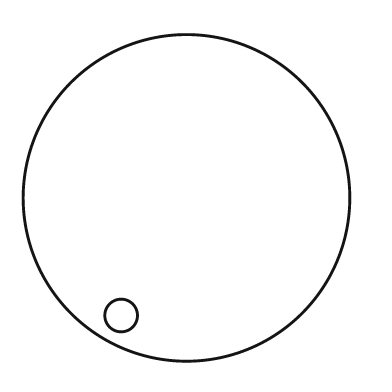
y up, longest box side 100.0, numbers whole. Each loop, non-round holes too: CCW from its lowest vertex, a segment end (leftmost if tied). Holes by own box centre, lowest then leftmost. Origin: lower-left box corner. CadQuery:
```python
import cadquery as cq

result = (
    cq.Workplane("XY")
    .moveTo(50.0, 50.0)
    .circle(50.0)
    .moveTo(30.0, 14.0)
    .circle(5.0)
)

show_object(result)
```